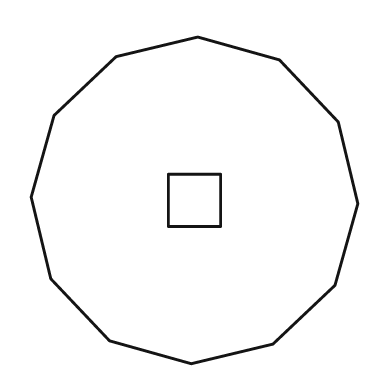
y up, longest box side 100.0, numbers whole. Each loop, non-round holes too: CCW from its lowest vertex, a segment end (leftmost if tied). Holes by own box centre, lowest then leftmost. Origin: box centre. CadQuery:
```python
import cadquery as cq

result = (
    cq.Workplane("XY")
    .moveTo(-1.0, -50.0)
    .lineTo(24.0, -44.0)
    .lineTo(43.0, -26.0)
    .lineTo(50.0, -1.0)
    .lineTo(44.0, 24.0)
    .lineTo(26.0, 43.0)
    .lineTo(1.0, 50.0)
    .lineTo(-24.0, 44.0)
    .lineTo(-43.0, 26.0)
    .lineTo(-50.0, 1.0)
    .lineTo(-44.0, -24.0)
    .lineTo(-26.0, -43.0)
    .close()
    .moveTo(-8.0, -8.0)
    .lineTo(8.0, -8.0)
    .lineTo(8.0, 8.0)
    .lineTo(-8.0, 8.0)
    .close()
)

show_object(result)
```